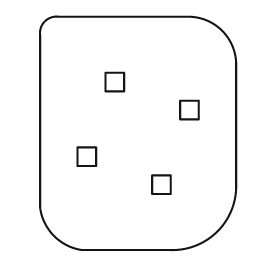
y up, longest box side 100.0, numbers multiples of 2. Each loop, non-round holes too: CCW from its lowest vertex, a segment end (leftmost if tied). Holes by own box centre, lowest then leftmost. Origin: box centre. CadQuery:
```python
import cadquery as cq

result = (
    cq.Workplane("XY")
    .moveTo(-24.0, -50.0)
    .lineTo(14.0, -50.0)
    .threePointArc((34.0, -42.0), (42.0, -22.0))
    .lineTo(42.0, 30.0)
    .threePointArc((36.0, 44.0), (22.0, 50.0))
    .lineTo(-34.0, 50.0)
    .threePointArc((-40.0, 48.0), (-42.0, 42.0))
    .lineTo(-42.0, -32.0)
    .threePointArc((-36.0, -44.0), (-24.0, -50.0))
    .close()
    .moveTo(6.0, -26.0)
    .lineTo(14.0, -26.0)
    .lineTo(14.0, -18.0)
    .lineTo(6.0, -18.0)
    .close()
    .moveTo(-26.0, -14.0)
    .lineTo(-18.0, -14.0)
    .lineTo(-18.0, -6.0)
    .lineTo(-26.0, -6.0)
    .close()
    .moveTo(18.0, 6.0)
    .lineTo(26.0, 6.0)
    .lineTo(26.0, 14.0)
    .lineTo(18.0, 14.0)
    .close()
    .moveTo(-14.0, 18.0)
    .lineTo(-6.0, 18.0)
    .lineTo(-6.0, 26.0)
    .lineTo(-14.0, 26.0)
    .close()
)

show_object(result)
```